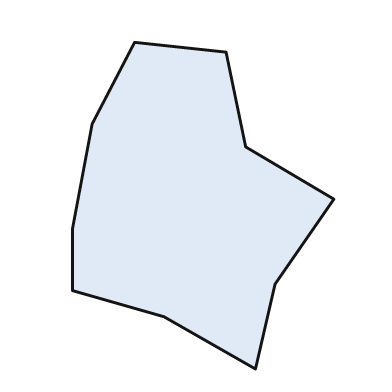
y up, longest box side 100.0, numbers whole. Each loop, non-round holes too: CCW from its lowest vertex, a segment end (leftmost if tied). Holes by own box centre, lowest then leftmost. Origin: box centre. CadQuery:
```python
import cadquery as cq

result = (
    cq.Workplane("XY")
    .moveTo(16.0, -50.0)
    .lineTo(22.0, -24.0)
    .lineTo(40.0, 2.0)
    .lineTo(13.0, 18.0)
    .lineTo(7.0, 47.0)
    .lineTo(-21.0, 50.0)
    .lineTo(-34.0, 25.0)
    .lineTo(-40.0, -7.0)
    .lineTo(-40.0, -26.0)
    .lineTo(-12.0, -34.0)
    .close()
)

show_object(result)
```